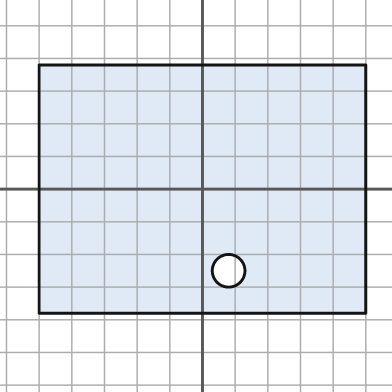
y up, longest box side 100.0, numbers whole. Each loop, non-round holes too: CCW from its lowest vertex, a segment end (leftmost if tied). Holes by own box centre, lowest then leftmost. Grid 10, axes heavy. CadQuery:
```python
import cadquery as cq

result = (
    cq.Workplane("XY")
    .moveTo(-50.0, -38.0)
    .lineTo(50.0, -38.0)
    .lineTo(50.0, 38.0)
    .lineTo(-50.0, 38.0)
    .close()
    .moveTo(8.0, -25.0)
    .circle(5.0)
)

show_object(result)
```